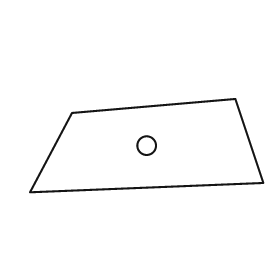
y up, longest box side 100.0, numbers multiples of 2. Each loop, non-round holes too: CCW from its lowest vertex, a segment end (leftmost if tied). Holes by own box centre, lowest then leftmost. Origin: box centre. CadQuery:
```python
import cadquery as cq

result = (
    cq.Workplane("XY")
    .moveTo(-50.0, -20.0)
    .lineTo(50.0, -16.0)
    .lineTo(38.0, 20.0)
    .lineTo(-32.0, 14.0)
    .close()
    .moveTo(0.0, 0.0)
    .circle(4.0)
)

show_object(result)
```